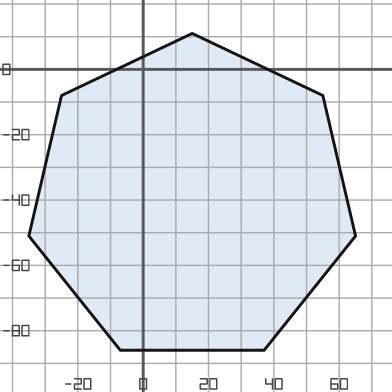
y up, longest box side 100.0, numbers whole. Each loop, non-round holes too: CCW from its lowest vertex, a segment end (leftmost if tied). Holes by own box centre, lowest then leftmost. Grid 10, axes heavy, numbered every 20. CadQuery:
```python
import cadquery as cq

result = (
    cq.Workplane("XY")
    .moveTo(-7.0, -86.0)
    .lineTo(37.0, -86.0)
    .lineTo(65.0, -51.0)
    .lineTo(55.0, -8.0)
    .lineTo(15.0, 11.0)
    .lineTo(-25.0, -8.0)
    .lineTo(-35.0, -51.0)
    .close()
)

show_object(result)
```